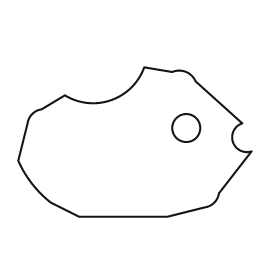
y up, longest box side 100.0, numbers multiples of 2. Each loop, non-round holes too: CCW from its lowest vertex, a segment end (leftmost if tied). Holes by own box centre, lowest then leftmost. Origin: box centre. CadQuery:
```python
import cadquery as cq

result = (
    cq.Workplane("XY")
    .moveTo(-24.0, -32.0)
    .lineTo(14.0, -32.0)
    .lineTo(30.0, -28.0)
    .threePointArc((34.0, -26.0), (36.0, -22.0))
    .lineTo(50.0, -4.0)
    .threePointArc((42.0, 0.0), (46.0, 8.0))
    .lineTo(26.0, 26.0)
    .threePointArc((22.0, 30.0), (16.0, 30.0))
    .lineTo(4.0, 32.0)
    .threePointArc((-10.0, 18.0), (-30.0, 20.0))
    .lineTo(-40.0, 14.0)
    .threePointArc((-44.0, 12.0), (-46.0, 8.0))
    .lineTo(-50.0, -8.0)
    .threePointArc((-44.0, -18.0), (-36.0, -26.0))
    .close()
    .moveTo(22.0, 6.0)
    .circle(6.0)
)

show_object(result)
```